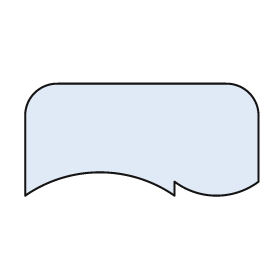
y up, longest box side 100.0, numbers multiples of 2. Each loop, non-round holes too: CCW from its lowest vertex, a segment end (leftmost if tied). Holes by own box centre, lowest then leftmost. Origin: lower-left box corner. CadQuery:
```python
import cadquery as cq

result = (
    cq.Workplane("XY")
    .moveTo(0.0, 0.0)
    .threePointArc((32.0, 10.0), (64.0, 0.0))
    .lineTo(64.0, 6.0)
    .threePointArc((82.0, 0.0), (100.0, 6.0))
    .lineTo(100.0, 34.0)
    .threePointArc((96.0, 44.0), (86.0, 48.0))
    .lineTo(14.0, 48.0)
    .threePointArc((4.0, 44.0), (0.0, 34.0))
    .close()
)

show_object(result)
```